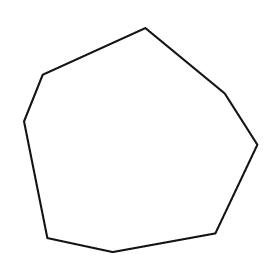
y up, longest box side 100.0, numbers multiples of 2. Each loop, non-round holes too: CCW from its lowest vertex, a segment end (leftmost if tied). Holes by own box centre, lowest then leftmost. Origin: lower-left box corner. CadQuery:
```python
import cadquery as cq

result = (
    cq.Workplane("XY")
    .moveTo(38.0, 0.0)
    .lineTo(82.0, 8.0)
    .lineTo(100.0, 46.0)
    .lineTo(86.0, 68.0)
    .lineTo(52.0, 96.0)
    .lineTo(8.0, 76.0)
    .lineTo(0.0, 56.0)
    .lineTo(10.0, 6.0)
    .close()
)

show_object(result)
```